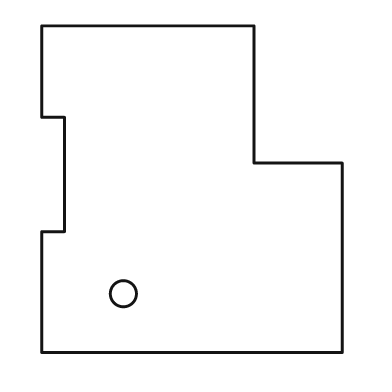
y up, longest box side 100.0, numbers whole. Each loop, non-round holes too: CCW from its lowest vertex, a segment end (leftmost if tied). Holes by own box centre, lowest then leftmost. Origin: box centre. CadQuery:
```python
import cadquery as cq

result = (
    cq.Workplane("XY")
    .moveTo(-46.0, -50.0)
    .lineTo(46.0, -50.0)
    .lineTo(46.0, 8.0)
    .lineTo(19.0, 8.0)
    .lineTo(19.0, 50.0)
    .lineTo(-46.0, 50.0)
    .lineTo(-46.0, 22.0)
    .lineTo(-39.0, 22.0)
    .lineTo(-39.0, -13.0)
    .lineTo(-46.0, -13.0)
    .close()
    .moveTo(-21.0, -32.0)
    .circle(4.0)
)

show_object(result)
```